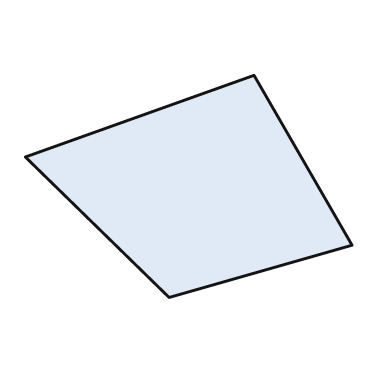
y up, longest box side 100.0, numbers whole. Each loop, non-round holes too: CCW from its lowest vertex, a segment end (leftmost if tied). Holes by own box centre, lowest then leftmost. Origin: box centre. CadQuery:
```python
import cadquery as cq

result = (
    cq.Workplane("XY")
    .moveTo(-6.0, -34.0)
    .lineTo(50.0, -18.0)
    .lineTo(20.0, 34.0)
    .lineTo(-50.0, 9.0)
    .close()
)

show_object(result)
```